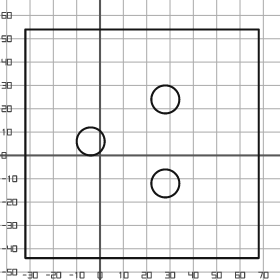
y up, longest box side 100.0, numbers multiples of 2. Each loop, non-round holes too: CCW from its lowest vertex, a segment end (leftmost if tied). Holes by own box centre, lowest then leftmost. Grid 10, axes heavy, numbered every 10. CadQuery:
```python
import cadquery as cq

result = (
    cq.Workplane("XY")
    .moveTo(-32.0, -44.0)
    .lineTo(68.0, -44.0)
    .lineTo(68.0, 54.0)
    .lineTo(-32.0, 54.0)
    .close()
    .moveTo(28.0, -12.0)
    .circle(6.0)
    .moveTo(-4.0, 6.0)
    .circle(6.0)
    .moveTo(28.0, 24.0)
    .circle(6.0)
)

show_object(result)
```